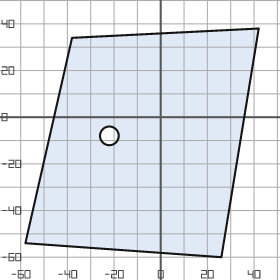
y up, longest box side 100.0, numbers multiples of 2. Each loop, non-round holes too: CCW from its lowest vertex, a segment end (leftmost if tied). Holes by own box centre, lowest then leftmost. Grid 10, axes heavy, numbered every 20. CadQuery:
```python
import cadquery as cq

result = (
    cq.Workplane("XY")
    .moveTo(26.0, -60.0)
    .lineTo(42.0, 38.0)
    .lineTo(-38.0, 34.0)
    .lineTo(-58.0, -54.0)
    .close()
    .moveTo(-22.0, -8.0)
    .circle(4.0)
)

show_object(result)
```